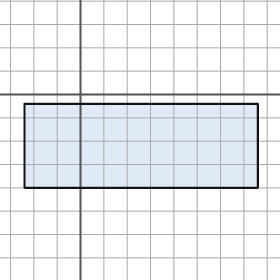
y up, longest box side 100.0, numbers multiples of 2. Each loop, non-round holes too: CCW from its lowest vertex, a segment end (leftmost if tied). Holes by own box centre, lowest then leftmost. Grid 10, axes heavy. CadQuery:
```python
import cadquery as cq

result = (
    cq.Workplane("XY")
    .moveTo(-24.0, -40.0)
    .lineTo(76.0, -40.0)
    .lineTo(76.0, -4.0)
    .lineTo(-24.0, -4.0)
    .close()
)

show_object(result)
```